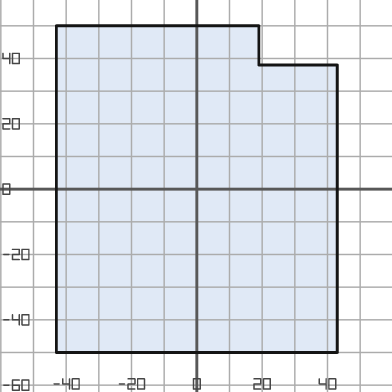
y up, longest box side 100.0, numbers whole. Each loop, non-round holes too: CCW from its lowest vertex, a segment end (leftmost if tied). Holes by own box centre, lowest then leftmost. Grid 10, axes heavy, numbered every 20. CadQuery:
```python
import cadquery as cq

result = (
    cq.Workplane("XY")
    .moveTo(-43.0, -50.0)
    .lineTo(43.0, -50.0)
    .lineTo(43.0, 38.0)
    .lineTo(19.0, 38.0)
    .lineTo(19.0, 50.0)
    .lineTo(-43.0, 50.0)
    .close()
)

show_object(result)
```